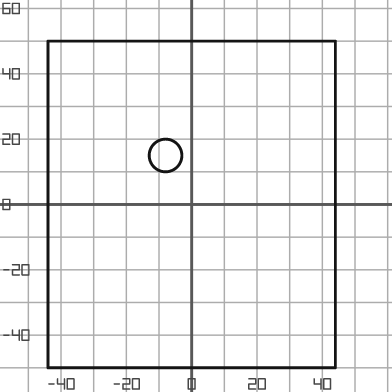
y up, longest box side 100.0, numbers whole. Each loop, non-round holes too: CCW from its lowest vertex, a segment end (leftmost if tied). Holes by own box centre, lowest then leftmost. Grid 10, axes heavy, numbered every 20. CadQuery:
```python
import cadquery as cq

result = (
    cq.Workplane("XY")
    .moveTo(-44.0, -50.0)
    .lineTo(44.0, -50.0)
    .lineTo(44.0, 50.0)
    .lineTo(-44.0, 50.0)
    .close()
    .moveTo(-8.0, 15.0)
    .circle(5.0)
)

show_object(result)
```